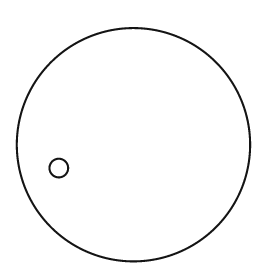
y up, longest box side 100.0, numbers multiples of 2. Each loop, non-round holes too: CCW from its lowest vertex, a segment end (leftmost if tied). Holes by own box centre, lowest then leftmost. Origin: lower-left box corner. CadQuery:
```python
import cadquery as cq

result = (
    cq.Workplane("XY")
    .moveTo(50.0, 50.0)
    .circle(50.0)
    .moveTo(18.0, 40.0)
    .circle(4.0)
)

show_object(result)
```